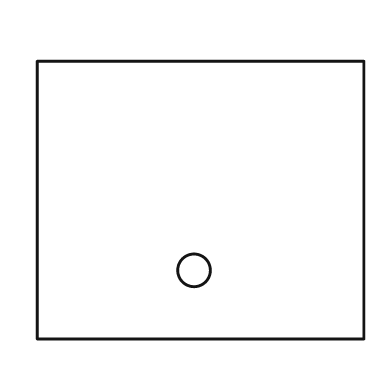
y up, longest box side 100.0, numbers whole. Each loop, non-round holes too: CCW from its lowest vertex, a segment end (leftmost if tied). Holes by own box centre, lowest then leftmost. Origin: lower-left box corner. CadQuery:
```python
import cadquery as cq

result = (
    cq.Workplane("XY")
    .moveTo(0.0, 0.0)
    .lineTo(100.0, 0.0)
    .lineTo(100.0, 85.0)
    .lineTo(0.0, 85.0)
    .close()
    .moveTo(48.0, 21.0)
    .circle(5.0)
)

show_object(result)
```